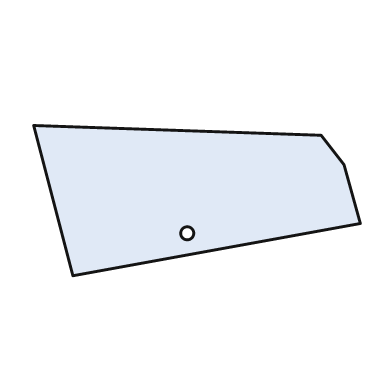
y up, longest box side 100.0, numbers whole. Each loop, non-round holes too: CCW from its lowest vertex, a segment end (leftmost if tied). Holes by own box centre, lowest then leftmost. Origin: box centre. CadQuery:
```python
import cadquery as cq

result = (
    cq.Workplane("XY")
    .moveTo(-38.0, -23.0)
    .lineTo(50.0, -7.0)
    .lineTo(45.0, 11.0)
    .lineTo(38.0, 20.0)
    .lineTo(-50.0, 23.0)
    .close()
    .moveTo(-3.0, -10.0)
    .circle(2.0)
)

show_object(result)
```